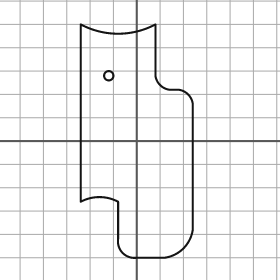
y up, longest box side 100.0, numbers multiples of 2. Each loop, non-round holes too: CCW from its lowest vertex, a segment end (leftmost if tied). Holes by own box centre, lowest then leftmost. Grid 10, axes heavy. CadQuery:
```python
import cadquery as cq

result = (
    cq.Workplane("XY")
    .moveTo(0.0, -50.0)
    .lineTo(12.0, -50.0)
    .threePointArc((20.0, -46.0), (24.0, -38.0))
    .lineTo(24.0, 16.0)
    .threePointArc((22.0, 20.0), (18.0, 22.0))
    .lineTo(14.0, 22.0)
    .threePointArc((10.0, 24.0), (8.0, 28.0))
    .lineTo(8.0, 50.0)
    .threePointArc((-8.0, 46.0), (-24.0, 50.0))
    .lineTo(-24.0, -26.0)
    .threePointArc((-16.0, -24.0), (-8.0, -26.0))
    .lineTo(-8.0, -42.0)
    .threePointArc((-6.0, -48.0), (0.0, -50.0))
    .close()
    .moveTo(-12.0, 28.0)
    .circle(2.0)
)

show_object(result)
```